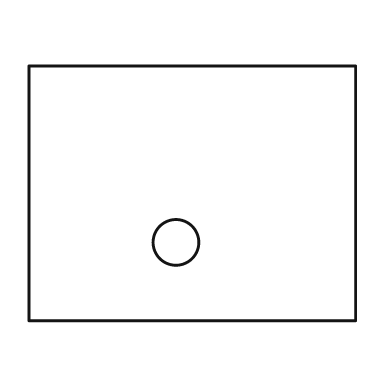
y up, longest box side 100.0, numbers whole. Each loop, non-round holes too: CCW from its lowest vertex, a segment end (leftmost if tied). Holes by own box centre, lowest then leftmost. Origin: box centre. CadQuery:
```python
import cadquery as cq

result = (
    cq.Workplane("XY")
    .moveTo(-50.0, -39.0)
    .lineTo(50.0, -39.0)
    .lineTo(50.0, 39.0)
    .lineTo(-50.0, 39.0)
    .close()
    .moveTo(-5.0, -15.0)
    .circle(7.0)
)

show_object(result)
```